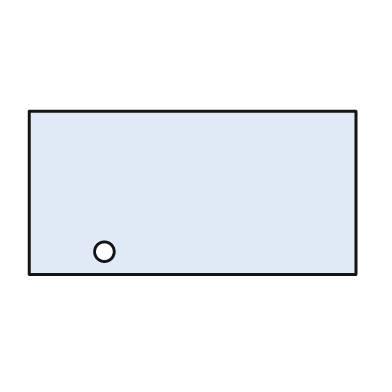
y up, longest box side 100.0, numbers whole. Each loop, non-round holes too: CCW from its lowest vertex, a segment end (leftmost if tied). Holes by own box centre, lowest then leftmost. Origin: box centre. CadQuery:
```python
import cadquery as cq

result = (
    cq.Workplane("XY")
    .moveTo(-50.0, -25.0)
    .lineTo(50.0, -25.0)
    .lineTo(50.0, 25.0)
    .lineTo(-50.0, 25.0)
    .close()
    .moveTo(-27.0, -18.0)
    .circle(3.0)
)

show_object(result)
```